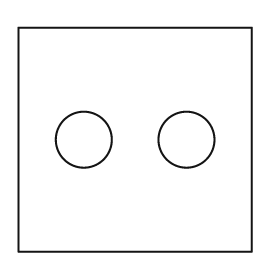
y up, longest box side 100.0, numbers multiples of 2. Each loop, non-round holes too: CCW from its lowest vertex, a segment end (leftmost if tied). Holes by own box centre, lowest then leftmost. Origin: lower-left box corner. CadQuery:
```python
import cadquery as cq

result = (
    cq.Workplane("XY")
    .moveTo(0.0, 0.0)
    .lineTo(100.0, 0.0)
    .lineTo(100.0, 96.0)
    .lineTo(0.0, 96.0)
    .close()
    .moveTo(28.0, 48.0)
    .circle(12.0)
    .moveTo(72.0, 48.0)
    .circle(12.0)
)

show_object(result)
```